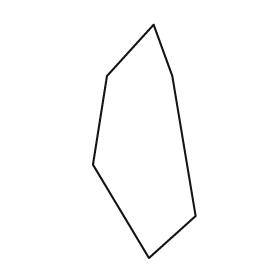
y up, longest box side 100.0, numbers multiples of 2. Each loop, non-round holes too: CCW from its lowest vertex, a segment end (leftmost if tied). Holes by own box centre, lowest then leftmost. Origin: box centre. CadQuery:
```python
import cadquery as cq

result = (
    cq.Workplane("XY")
    .moveTo(2.0, -50.0)
    .lineTo(22.0, -32.0)
    .lineTo(12.0, 28.0)
    .lineTo(4.0, 50.0)
    .lineTo(-16.0, 28.0)
    .lineTo(-22.0, -10.0)
    .close()
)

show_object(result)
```